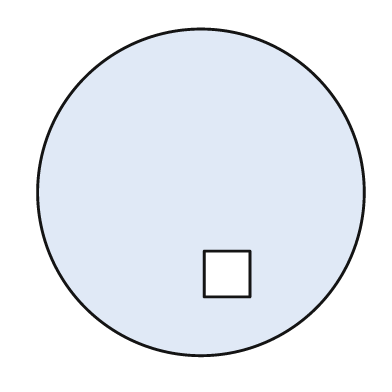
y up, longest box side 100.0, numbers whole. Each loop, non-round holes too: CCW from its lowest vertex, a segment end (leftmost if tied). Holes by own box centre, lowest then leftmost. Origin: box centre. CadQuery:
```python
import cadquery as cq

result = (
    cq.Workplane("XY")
    .moveTo(0.0, 0.0)
    .circle(50.0)
    .moveTo(1.0, -32.0)
    .lineTo(15.0, -32.0)
    .lineTo(15.0, -18.0)
    .lineTo(1.0, -18.0)
    .close()
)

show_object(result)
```